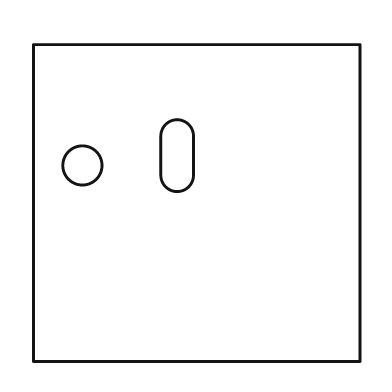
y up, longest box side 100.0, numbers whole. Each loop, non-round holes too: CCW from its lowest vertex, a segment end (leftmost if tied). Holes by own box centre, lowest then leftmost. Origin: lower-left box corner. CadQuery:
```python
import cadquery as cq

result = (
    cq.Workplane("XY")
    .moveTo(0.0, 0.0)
    .lineTo(100.0, 0.0)
    .lineTo(100.0, 97.0)
    .lineTo(0.0, 97.0)
    .close()
    .moveTo(15.0, 60.0)
    .circle(6.0)
    .moveTo(39.0, 57.0)
    .threePointArc((44.0, 52.0), (49.0, 57.0))
    .lineTo(49.0, 69.0)
    .threePointArc((44.0, 74.0), (39.0, 69.0))
    .close()
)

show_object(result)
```